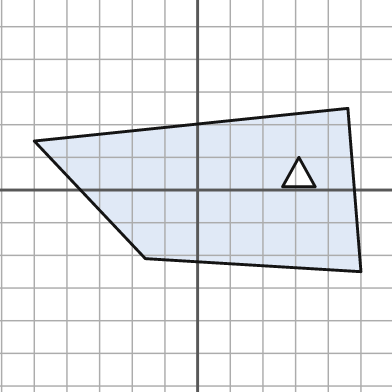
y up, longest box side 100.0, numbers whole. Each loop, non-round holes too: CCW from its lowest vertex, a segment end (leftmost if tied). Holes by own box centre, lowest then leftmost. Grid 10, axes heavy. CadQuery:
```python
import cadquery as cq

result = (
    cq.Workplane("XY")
    .moveTo(50.0, -25.0)
    .lineTo(46.0, 25.0)
    .lineTo(-50.0, 15.0)
    .lineTo(-16.0, -21.0)
    .close()
    .moveTo(26.0, 1.0)
    .lineTo(36.0, 1.0)
    .lineTo(31.0, 10.0)
    .close()
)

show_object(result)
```